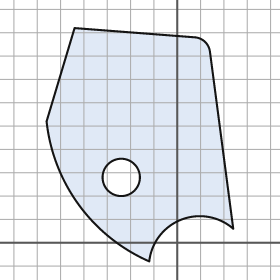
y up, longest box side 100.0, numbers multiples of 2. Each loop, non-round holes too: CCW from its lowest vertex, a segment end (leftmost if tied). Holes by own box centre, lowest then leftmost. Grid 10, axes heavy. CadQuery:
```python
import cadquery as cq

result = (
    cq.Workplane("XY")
    .moveTo(-12.0, -8.0)
    .threePointArc((2.0, 10.0), (24.0, 6.0))
    .lineTo(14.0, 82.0)
    .threePointArc((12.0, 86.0), (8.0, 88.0))
    .lineTo(-44.0, 92.0)
    .lineTo(-56.0, 52.0)
    .threePointArc((-42.0, 16.0), (-12.0, -8.0))
    .close()
    .moveTo(-24.0, 28.0)
    .circle(8.0)
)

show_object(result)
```